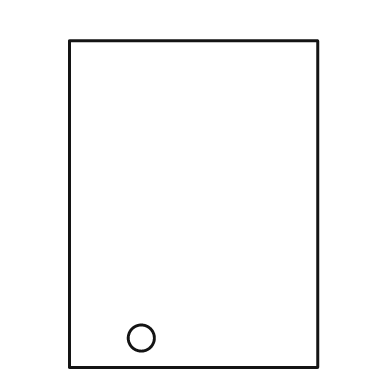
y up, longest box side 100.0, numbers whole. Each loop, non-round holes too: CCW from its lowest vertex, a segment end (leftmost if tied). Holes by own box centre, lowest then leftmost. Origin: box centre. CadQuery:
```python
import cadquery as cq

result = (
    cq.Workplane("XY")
    .moveTo(-38.0, -50.0)
    .lineTo(38.0, -50.0)
    .lineTo(38.0, 50.0)
    .lineTo(-38.0, 50.0)
    .close()
    .moveTo(-16.0, -41.0)
    .circle(4.0)
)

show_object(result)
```